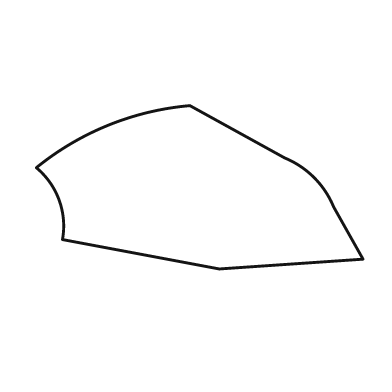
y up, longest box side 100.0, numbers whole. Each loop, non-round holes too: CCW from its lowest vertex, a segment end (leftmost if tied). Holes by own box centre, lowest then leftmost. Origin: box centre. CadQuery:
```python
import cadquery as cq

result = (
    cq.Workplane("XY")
    .moveTo(6.0, -25.0)
    .lineTo(50.0, -22.0)
    .lineTo(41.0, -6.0)
    .threePointArc((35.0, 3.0), (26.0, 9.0))
    .lineTo(-3.0, 25.0)
    .threePointArc((-28.0, 19.0), (-50.0, 6.0))
    .threePointArc((-43.0, -4.0), (-42.0, -16.0))
    .close()
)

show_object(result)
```